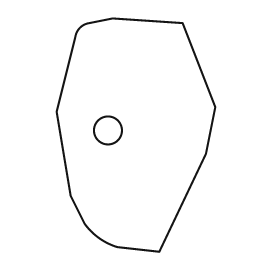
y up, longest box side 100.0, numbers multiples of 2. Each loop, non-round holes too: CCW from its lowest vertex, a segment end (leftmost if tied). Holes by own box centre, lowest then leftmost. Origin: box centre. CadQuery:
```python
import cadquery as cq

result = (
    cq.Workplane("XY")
    .moveTo(10.0, -50.0)
    .lineTo(30.0, -8.0)
    .lineTo(34.0, 12.0)
    .lineTo(20.0, 48.0)
    .lineTo(-10.0, 50.0)
    .lineTo(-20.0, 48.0)
    .threePointArc((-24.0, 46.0), (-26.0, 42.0))
    .lineTo(-34.0, 10.0)
    .lineTo(-28.0, -26.0)
    .lineTo(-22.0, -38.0)
    .threePointArc((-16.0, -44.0), (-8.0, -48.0))
    .close()
    .moveTo(-12.0, 2.0)
    .circle(6.0)
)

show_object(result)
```